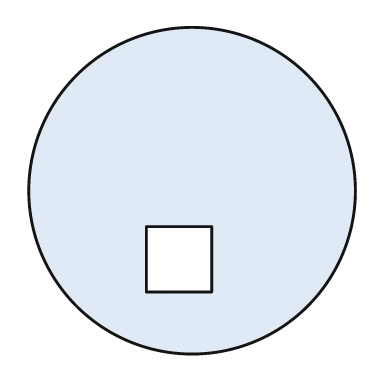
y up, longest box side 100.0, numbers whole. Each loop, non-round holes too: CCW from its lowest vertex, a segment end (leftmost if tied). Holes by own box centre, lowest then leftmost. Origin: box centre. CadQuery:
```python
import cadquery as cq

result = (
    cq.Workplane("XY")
    .moveTo(0.0, 0.0)
    .circle(50.0)
    .moveTo(-14.0, -31.0)
    .lineTo(6.0, -31.0)
    .lineTo(6.0, -11.0)
    .lineTo(-14.0, -11.0)
    .close()
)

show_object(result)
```